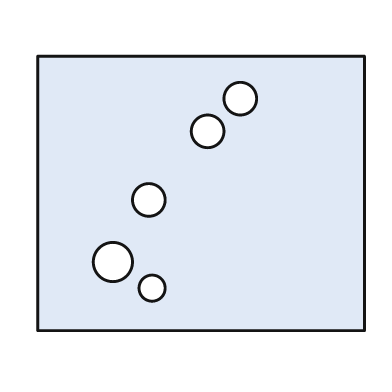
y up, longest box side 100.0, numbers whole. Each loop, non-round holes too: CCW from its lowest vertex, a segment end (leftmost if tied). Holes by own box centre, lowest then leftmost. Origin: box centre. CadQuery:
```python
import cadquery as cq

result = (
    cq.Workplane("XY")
    .moveTo(-50.0, -42.0)
    .lineTo(50.0, -42.0)
    .lineTo(50.0, 42.0)
    .lineTo(-50.0, 42.0)
    .close()
    .moveTo(-15.0, -29.0)
    .circle(4.0)
    .moveTo(-27.0, -21.0)
    .circle(6.0)
    .moveTo(-16.0, -2.0)
    .circle(5.0)
    .moveTo(2.0, 19.0)
    .circle(5.0)
    .moveTo(12.0, 29.0)
    .circle(5.0)
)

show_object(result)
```